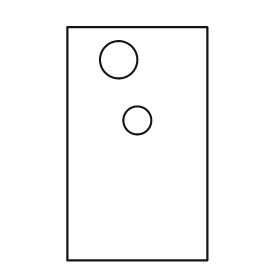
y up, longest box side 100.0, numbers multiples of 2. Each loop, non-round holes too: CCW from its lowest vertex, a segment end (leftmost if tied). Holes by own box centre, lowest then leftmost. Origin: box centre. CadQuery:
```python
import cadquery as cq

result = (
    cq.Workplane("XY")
    .moveTo(-30.0, -50.0)
    .lineTo(30.0, -50.0)
    .lineTo(30.0, 50.0)
    .lineTo(-30.0, 50.0)
    .close()
    .moveTo(0.0, 10.0)
    .circle(6.0)
    .moveTo(-8.0, 36.0)
    .circle(8.0)
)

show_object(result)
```